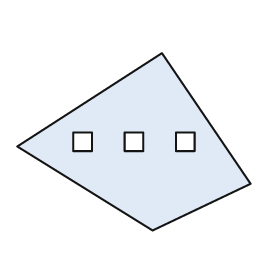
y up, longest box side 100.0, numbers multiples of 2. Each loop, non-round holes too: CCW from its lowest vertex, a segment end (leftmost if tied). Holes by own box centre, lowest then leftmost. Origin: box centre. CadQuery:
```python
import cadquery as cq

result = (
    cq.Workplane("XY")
    .moveTo(8.0, -38.0)
    .lineTo(50.0, -18.0)
    .lineTo(12.0, 38.0)
    .lineTo(-50.0, -2.0)
    .close()
    .moveTo(-26.0, -4.0)
    .lineTo(-18.0, -4.0)
    .lineTo(-18.0, 4.0)
    .lineTo(-26.0, 4.0)
    .close()
    .moveTo(-4.0, -4.0)
    .lineTo(4.0, -4.0)
    .lineTo(4.0, 4.0)
    .lineTo(-4.0, 4.0)
    .close()
    .moveTo(18.0, -4.0)
    .lineTo(26.0, -4.0)
    .lineTo(26.0, 4.0)
    .lineTo(18.0, 4.0)
    .close()
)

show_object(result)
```